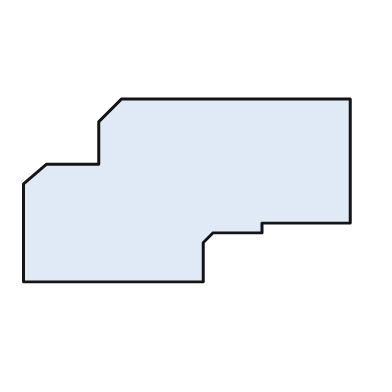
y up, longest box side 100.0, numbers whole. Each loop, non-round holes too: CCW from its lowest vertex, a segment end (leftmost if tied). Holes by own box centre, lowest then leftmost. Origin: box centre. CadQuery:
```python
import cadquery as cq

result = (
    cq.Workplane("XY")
    .moveTo(-50.0, -28.0)
    .lineTo(5.0, -28.0)
    .lineTo(5.0, -16.0)
    .lineTo(8.0, -13.0)
    .lineTo(23.0, -13.0)
    .lineTo(23.0, -10.0)
    .lineTo(50.0, -10.0)
    .lineTo(50.0, 28.0)
    .lineTo(-20.0, 28.0)
    .lineTo(-27.0, 21.0)
    .lineTo(-27.0, 8.0)
    .lineTo(-43.0, 8.0)
    .lineTo(-50.0, 2.0)
    .close()
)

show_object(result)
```